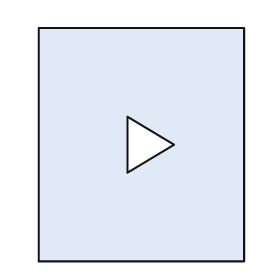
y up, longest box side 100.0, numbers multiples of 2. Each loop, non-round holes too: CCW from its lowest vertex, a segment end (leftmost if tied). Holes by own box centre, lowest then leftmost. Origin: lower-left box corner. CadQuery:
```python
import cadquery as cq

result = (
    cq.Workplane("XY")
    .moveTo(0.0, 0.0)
    .lineTo(88.0, 0.0)
    .lineTo(88.0, 100.0)
    .lineTo(0.0, 100.0)
    .close()
    .moveTo(38.0, 38.0)
    .lineTo(58.0, 50.0)
    .lineTo(38.0, 62.0)
    .close()
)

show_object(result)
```